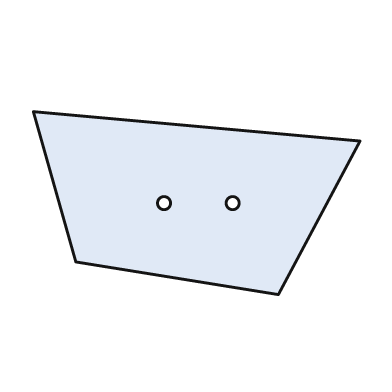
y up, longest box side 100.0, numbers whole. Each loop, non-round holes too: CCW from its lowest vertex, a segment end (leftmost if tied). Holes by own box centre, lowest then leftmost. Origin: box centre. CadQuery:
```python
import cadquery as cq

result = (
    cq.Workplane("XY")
    .moveTo(25.0, -28.0)
    .lineTo(50.0, 19.0)
    .lineTo(-50.0, 28.0)
    .lineTo(-37.0, -18.0)
    .close()
    .moveTo(-10.0, 0.0)
    .circle(2.0)
    .moveTo(11.0, 0.0)
    .circle(2.0)
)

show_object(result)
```